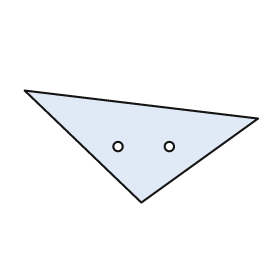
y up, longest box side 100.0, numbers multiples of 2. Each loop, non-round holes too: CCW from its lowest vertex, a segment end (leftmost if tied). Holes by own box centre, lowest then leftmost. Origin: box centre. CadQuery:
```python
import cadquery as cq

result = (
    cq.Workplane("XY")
    .moveTo(0.0, -24.0)
    .lineTo(50.0, 12.0)
    .lineTo(-50.0, 24.0)
    .close()
    .moveTo(-10.0, 0.0)
    .circle(2.0)
    .moveTo(12.0, 0.0)
    .circle(2.0)
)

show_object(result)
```